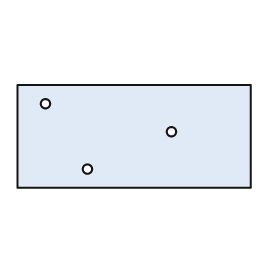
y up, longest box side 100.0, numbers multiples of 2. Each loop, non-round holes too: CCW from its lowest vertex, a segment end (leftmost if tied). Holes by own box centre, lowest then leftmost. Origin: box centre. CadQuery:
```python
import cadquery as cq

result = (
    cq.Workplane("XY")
    .moveTo(-50.0, -22.0)
    .lineTo(50.0, -22.0)
    .lineTo(50.0, 22.0)
    .lineTo(-50.0, 22.0)
    .close()
    .moveTo(-20.0, -14.0)
    .circle(2.0)
    .moveTo(16.0, 2.0)
    .circle(2.0)
    .moveTo(-38.0, 14.0)
    .circle(2.0)
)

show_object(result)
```